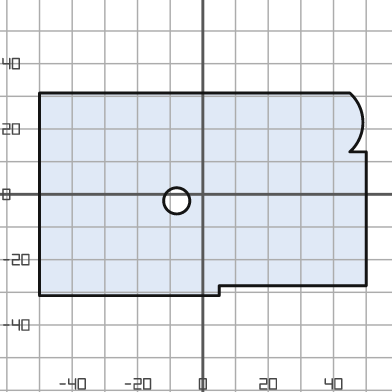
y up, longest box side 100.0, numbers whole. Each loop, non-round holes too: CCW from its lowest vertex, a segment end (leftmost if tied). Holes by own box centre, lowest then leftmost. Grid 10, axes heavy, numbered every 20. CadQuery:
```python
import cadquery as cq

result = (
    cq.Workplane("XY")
    .moveTo(-50.0, -31.0)
    .lineTo(5.0, -31.0)
    .lineTo(5.0, -28.0)
    .lineTo(50.0, -28.0)
    .lineTo(50.0, 13.0)
    .lineTo(45.0, 13.0)
    .threePointArc((49.0, 22.0), (45.0, 31.0))
    .lineTo(-50.0, 31.0)
    .close()
    .moveTo(-8.0, -2.0)
    .circle(4.0)
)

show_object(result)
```